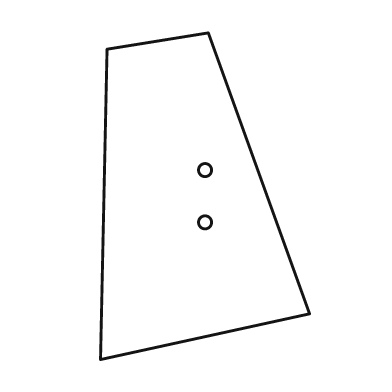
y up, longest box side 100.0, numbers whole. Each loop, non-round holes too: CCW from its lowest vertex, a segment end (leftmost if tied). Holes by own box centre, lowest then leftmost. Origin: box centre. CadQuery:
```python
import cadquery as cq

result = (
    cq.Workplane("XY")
    .moveTo(-32.0, -50.0)
    .lineTo(32.0, -36.0)
    .lineTo(1.0, 50.0)
    .lineTo(-30.0, 45.0)
    .close()
    .moveTo(0.0, -8.0)
    .circle(2.0)
    .moveTo(0.0, 8.0)
    .circle(2.0)
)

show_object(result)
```